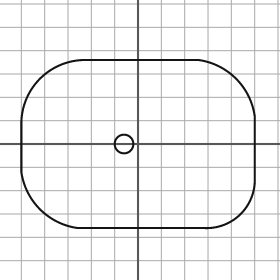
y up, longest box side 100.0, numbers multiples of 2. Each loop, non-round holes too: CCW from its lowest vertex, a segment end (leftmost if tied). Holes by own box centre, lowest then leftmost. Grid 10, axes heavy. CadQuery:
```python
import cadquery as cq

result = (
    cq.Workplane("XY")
    .moveTo(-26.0, -36.0)
    .lineTo(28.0, -36.0)
    .threePointArc((44.0, -30.0), (50.0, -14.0))
    .lineTo(50.0, 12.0)
    .threePointArc((42.0, 28.0), (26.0, 36.0))
    .lineTo(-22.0, 36.0)
    .threePointArc((-42.0, 28.0), (-50.0, 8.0))
    .lineTo(-50.0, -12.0)
    .threePointArc((-42.0, -28.0), (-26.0, -36.0))
    .close()
    .moveTo(-6.0, 0.0)
    .circle(4.0)
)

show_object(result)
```